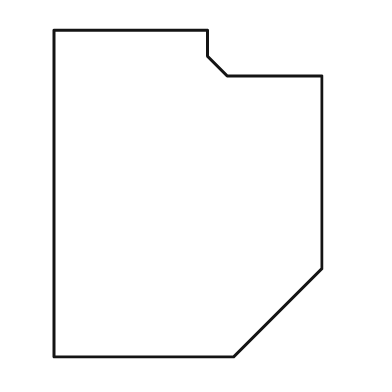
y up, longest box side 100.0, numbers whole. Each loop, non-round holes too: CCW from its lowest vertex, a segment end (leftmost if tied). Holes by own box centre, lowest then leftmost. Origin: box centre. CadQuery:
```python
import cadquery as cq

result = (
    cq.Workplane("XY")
    .moveTo(-41.0, -50.0)
    .lineTo(14.0, -50.0)
    .lineTo(41.0, -23.0)
    .lineTo(41.0, 36.0)
    .lineTo(12.0, 36.0)
    .lineTo(6.0, 42.0)
    .lineTo(6.0, 50.0)
    .lineTo(-41.0, 50.0)
    .close()
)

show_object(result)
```